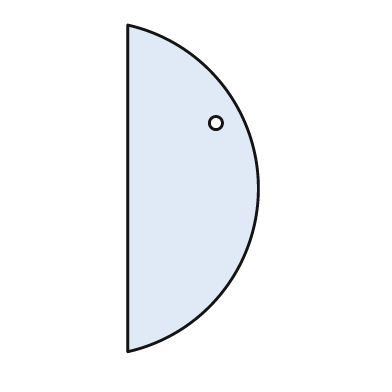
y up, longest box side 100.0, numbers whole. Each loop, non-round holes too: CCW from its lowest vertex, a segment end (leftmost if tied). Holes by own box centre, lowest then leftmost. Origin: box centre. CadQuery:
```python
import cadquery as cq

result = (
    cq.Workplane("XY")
    .moveTo(-20.0, -50.0)
    .threePointArc((20.0, 0.0), (-20.0, 50.0))
    .close()
    .moveTo(7.0, 20.0)
    .circle(2.0)
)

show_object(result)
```